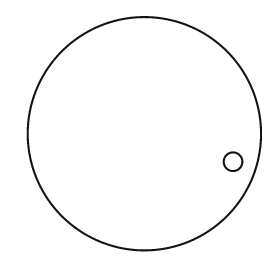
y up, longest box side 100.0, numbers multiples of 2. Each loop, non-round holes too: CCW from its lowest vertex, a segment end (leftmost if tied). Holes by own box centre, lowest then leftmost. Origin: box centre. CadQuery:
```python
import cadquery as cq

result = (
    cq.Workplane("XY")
    .moveTo(0.0, 0.0)
    .circle(50.0)
    .moveTo(38.0, -12.0)
    .circle(4.0)
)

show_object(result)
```